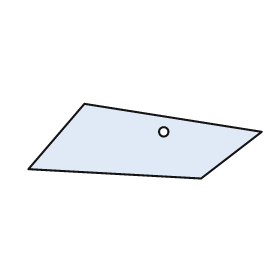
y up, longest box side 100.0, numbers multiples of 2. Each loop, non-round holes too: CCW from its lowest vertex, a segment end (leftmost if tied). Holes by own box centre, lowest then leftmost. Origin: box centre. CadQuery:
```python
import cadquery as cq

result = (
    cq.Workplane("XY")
    .moveTo(24.0, -16.0)
    .lineTo(50.0, 4.0)
    .lineTo(-26.0, 16.0)
    .lineTo(-50.0, -12.0)
    .close()
    .moveTo(8.0, 4.0)
    .circle(2.0)
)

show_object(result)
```